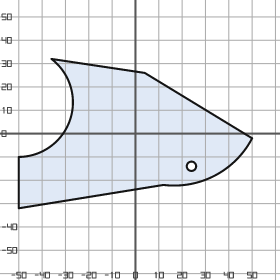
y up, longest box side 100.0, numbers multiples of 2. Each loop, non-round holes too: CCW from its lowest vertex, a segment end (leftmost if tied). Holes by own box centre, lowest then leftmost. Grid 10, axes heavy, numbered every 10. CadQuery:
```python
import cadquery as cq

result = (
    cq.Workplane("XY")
    .moveTo(-50.0, -32.0)
    .lineTo(12.0, -22.0)
    .threePointArc((34.0, -18.0), (50.0, -2.0))
    .lineTo(4.0, 26.0)
    .lineTo(-36.0, 32.0)
    .threePointArc((-28.0, 6.0), (-50.0, -10.0))
    .close()
    .moveTo(24.0, -14.0)
    .circle(2.0)
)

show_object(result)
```